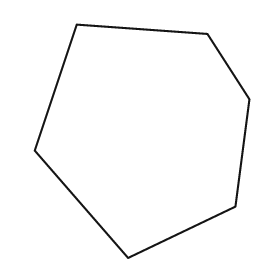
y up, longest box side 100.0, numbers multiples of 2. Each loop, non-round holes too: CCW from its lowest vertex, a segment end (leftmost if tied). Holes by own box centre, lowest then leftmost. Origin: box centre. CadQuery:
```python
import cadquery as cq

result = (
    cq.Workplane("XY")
    .moveTo(-6.0, -50.0)
    .lineTo(40.0, -28.0)
    .lineTo(46.0, 18.0)
    .lineTo(28.0, 46.0)
    .lineTo(-28.0, 50.0)
    .lineTo(-46.0, -4.0)
    .close()
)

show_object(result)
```